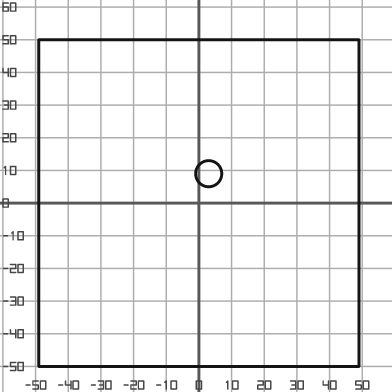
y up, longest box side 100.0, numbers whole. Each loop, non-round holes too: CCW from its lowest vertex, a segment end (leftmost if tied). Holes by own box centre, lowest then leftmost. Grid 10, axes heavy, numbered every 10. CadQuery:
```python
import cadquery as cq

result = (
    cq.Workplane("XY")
    .moveTo(-49.0, -50.0)
    .lineTo(49.0, -50.0)
    .lineTo(49.0, 50.0)
    .lineTo(-49.0, 50.0)
    .close()
    .moveTo(3.0, 9.0)
    .circle(4.0)
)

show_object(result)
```